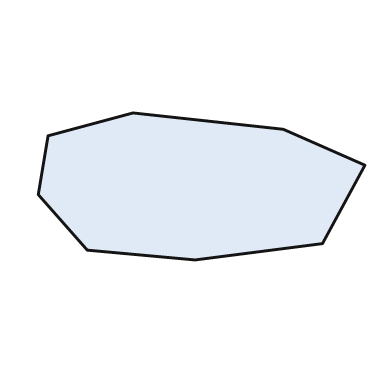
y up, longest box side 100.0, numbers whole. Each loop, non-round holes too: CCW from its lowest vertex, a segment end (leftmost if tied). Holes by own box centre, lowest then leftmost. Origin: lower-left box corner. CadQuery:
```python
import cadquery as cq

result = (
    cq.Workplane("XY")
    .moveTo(48.0, 0.0)
    .lineTo(87.0, 5.0)
    .lineTo(100.0, 29.0)
    .lineTo(75.0, 40.0)
    .lineTo(29.0, 45.0)
    .lineTo(3.0, 38.0)
    .lineTo(0.0, 20.0)
    .lineTo(15.0, 3.0)
    .close()
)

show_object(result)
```